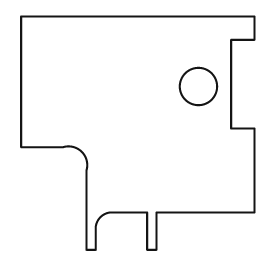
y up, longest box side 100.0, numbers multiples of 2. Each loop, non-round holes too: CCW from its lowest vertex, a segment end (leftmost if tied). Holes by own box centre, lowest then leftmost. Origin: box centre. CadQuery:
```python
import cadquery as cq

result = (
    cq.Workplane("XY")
    .moveTo(-22.0, -50.0)
    .lineTo(-18.0, -50.0)
    .lineTo(-18.0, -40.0)
    .threePointArc((-16.0, -36.0), (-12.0, -34.0))
    .lineTo(4.0, -34.0)
    .lineTo(4.0, -50.0)
    .lineTo(8.0, -50.0)
    .lineTo(8.0, -34.0)
    .lineTo(50.0, -34.0)
    .lineTo(50.0, 2.0)
    .lineTo(40.0, 2.0)
    .lineTo(40.0, 40.0)
    .lineTo(50.0, 40.0)
    .lineTo(50.0, 50.0)
    .lineTo(-50.0, 50.0)
    .lineTo(-50.0, -6.0)
    .lineTo(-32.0, -6.0)
    .threePointArc((-24.0, -8.0), (-22.0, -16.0))
    .close()
    .moveTo(26.0, 20.0)
    .circle(8.0)
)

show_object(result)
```